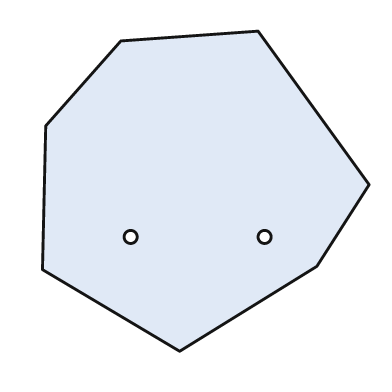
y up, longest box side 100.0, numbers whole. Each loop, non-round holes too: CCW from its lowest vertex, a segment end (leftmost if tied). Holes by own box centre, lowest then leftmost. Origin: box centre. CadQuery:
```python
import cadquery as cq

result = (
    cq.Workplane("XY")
    .moveTo(-8.0, -49.0)
    .lineTo(34.0, -23.0)
    .lineTo(50.0, 2.0)
    .lineTo(16.0, 49.0)
    .lineTo(-26.0, 46.0)
    .lineTo(-49.0, 20.0)
    .lineTo(-50.0, -24.0)
    .close()
    .moveTo(-23.0, -14.0)
    .circle(2.0)
    .moveTo(18.0, -14.0)
    .circle(2.0)
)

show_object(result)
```